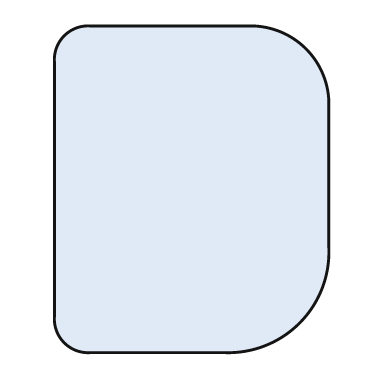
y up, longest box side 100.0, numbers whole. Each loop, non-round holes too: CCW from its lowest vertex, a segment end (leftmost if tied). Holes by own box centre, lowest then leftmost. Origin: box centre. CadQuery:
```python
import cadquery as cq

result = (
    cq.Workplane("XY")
    .moveTo(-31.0, -50.0)
    .lineTo(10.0, -50.0)
    .threePointArc((33.0, -41.0), (42.0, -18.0))
    .lineTo(42.0, 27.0)
    .threePointArc((35.0, 43.0), (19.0, 50.0))
    .lineTo(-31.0, 50.0)
    .threePointArc((-39.0, 47.0), (-42.0, 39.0))
    .lineTo(-42.0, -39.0)
    .threePointArc((-39.0, -47.0), (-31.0, -50.0))
    .close()
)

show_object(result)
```